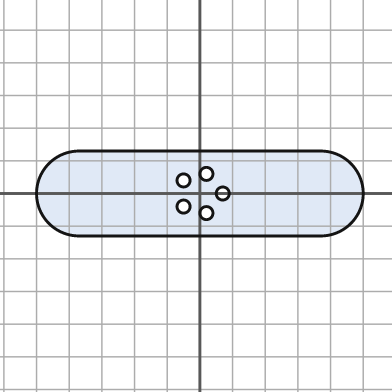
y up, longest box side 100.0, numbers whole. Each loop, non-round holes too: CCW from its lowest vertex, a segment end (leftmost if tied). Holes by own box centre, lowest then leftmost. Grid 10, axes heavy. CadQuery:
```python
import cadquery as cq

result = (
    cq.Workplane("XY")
    .moveTo(-37.0, -13.0)
    .lineTo(37.0, -13.0)
    .threePointArc((50.0, 0.0), (37.0, 13.0))
    .lineTo(-37.0, 13.0)
    .threePointArc((-50.0, 0.0), (-37.0, -13.0))
    .close()
    .moveTo(2.0, -6.0)
    .circle(2.0)
    .moveTo(-5.0, -4.0)
    .circle(2.0)
    .moveTo(7.0, 0.0)
    .circle(2.0)
    .moveTo(-5.0, 4.0)
    .circle(2.0)
    .moveTo(2.0, 6.0)
    .circle(2.0)
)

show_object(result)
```